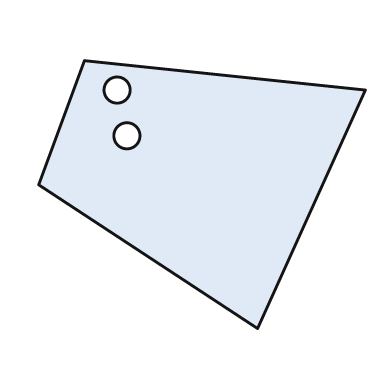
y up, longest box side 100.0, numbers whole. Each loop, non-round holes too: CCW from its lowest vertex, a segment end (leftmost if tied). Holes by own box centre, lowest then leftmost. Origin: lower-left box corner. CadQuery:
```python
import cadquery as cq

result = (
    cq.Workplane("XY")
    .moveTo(67.0, 0.0)
    .lineTo(100.0, 73.0)
    .lineTo(14.0, 82.0)
    .lineTo(0.0, 44.0)
    .close()
    .moveTo(27.0, 59.0)
    .circle(4.0)
    .moveTo(24.0, 73.0)
    .circle(4.0)
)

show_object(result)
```